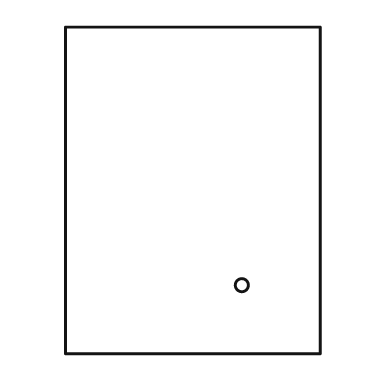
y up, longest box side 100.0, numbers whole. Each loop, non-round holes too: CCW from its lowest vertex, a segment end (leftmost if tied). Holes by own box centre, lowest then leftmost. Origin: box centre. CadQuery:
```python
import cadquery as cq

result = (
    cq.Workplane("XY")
    .moveTo(-39.0, -50.0)
    .lineTo(39.0, -50.0)
    .lineTo(39.0, 50.0)
    .lineTo(-39.0, 50.0)
    .close()
    .moveTo(15.0, -29.0)
    .circle(2.0)
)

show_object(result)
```